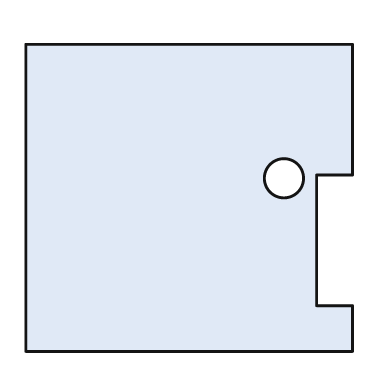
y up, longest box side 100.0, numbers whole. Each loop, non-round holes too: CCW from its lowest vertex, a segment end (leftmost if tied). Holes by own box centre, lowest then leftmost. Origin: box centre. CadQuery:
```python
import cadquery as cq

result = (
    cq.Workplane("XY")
    .moveTo(-50.0, -47.0)
    .lineTo(50.0, -47.0)
    .lineTo(50.0, -33.0)
    .lineTo(39.0, -33.0)
    .lineTo(39.0, 7.0)
    .lineTo(50.0, 7.0)
    .lineTo(50.0, 47.0)
    .lineTo(-50.0, 47.0)
    .close()
    .moveTo(29.0, 6.0)
    .circle(6.0)
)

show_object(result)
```